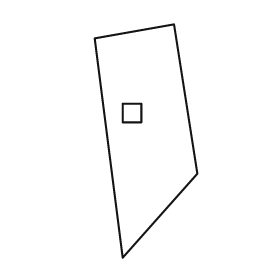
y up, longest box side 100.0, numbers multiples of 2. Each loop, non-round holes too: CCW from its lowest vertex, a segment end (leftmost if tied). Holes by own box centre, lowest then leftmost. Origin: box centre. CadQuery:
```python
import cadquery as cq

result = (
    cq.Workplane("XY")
    .moveTo(-10.0, -50.0)
    .lineTo(22.0, -14.0)
    .lineTo(12.0, 50.0)
    .lineTo(-22.0, 44.0)
    .close()
    .moveTo(-10.0, 8.0)
    .lineTo(-2.0, 8.0)
    .lineTo(-2.0, 16.0)
    .lineTo(-10.0, 16.0)
    .close()
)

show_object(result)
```